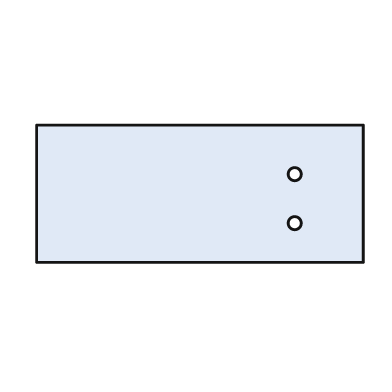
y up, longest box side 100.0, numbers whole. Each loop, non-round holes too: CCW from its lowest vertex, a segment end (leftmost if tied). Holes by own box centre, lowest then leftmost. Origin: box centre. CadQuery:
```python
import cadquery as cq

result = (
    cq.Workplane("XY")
    .moveTo(-50.0, -21.0)
    .lineTo(50.0, -21.0)
    .lineTo(50.0, 21.0)
    .lineTo(-50.0, 21.0)
    .close()
    .moveTo(29.0, -9.0)
    .circle(2.0)
    .moveTo(29.0, 6.0)
    .circle(2.0)
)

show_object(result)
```